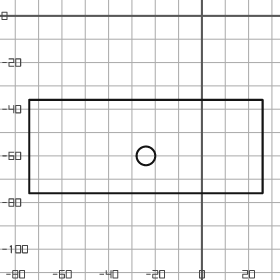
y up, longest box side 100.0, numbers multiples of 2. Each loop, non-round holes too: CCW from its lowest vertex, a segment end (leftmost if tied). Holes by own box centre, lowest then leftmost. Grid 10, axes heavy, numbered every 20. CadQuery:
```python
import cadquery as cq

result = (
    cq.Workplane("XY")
    .moveTo(-74.0, -76.0)
    .lineTo(26.0, -76.0)
    .lineTo(26.0, -36.0)
    .lineTo(-74.0, -36.0)
    .close()
    .moveTo(-24.0, -60.0)
    .circle(4.0)
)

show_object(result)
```